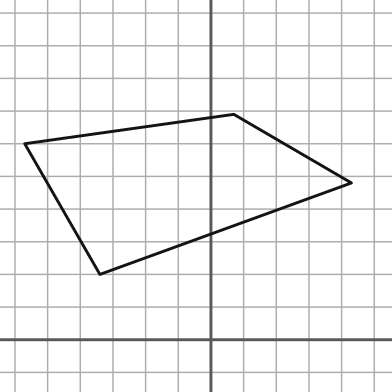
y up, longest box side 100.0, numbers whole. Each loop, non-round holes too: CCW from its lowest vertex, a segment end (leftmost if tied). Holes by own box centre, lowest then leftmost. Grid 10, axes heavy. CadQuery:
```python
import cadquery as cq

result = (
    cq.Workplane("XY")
    .moveTo(-34.0, 20.0)
    .lineTo(43.0, 48.0)
    .lineTo(7.0, 69.0)
    .lineTo(-57.0, 60.0)
    .close()
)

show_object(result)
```